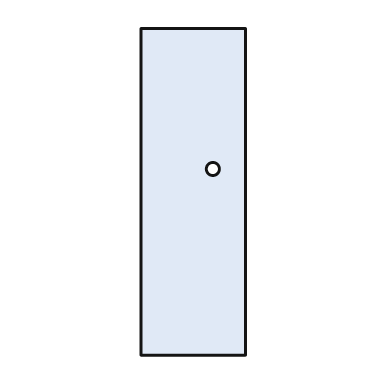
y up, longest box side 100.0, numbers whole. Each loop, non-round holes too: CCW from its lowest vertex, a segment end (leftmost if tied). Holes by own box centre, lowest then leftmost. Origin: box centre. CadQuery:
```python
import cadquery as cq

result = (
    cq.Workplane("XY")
    .moveTo(-16.0, -50.0)
    .lineTo(16.0, -50.0)
    .lineTo(16.0, 50.0)
    .lineTo(-16.0, 50.0)
    .close()
    .moveTo(6.0, 7.0)
    .circle(2.0)
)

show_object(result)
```